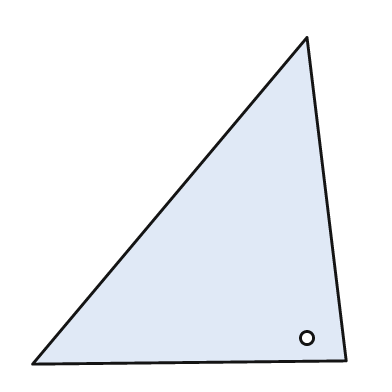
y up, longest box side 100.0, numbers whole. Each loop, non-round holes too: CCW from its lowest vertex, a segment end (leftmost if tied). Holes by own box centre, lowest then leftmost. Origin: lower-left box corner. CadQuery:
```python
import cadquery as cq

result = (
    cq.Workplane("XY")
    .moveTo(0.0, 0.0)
    .lineTo(96.0, 1.0)
    .lineTo(84.0, 100.0)
    .close()
    .moveTo(84.0, 8.0)
    .circle(2.0)
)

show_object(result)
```